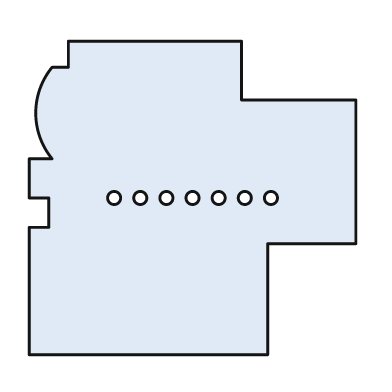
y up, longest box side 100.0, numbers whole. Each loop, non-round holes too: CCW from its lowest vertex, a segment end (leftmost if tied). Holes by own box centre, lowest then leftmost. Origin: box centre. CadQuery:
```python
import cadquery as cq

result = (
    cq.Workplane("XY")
    .moveTo(-50.0, -48.0)
    .lineTo(23.0, -48.0)
    .lineTo(23.0, -14.0)
    .lineTo(50.0, -14.0)
    .lineTo(50.0, 30.0)
    .lineTo(15.0, 30.0)
    .lineTo(15.0, 48.0)
    .lineTo(-38.0, 48.0)
    .lineTo(-38.0, 40.0)
    .lineTo(-43.0, 40.0)
    .threePointArc((-48.0, 26.0), (-43.0, 12.0))
    .lineTo(-50.0, 12.0)
    .lineTo(-50.0, 0.0)
    .lineTo(-44.0, 0.0)
    .lineTo(-44.0, -9.0)
    .lineTo(-50.0, -9.0)
    .close()
    .moveTo(-24.0, 0.0)
    .circle(2.0)
    .moveTo(-16.0, 0.0)
    .circle(2.0)
    .moveTo(-8.0, 0.0)
    .circle(2.0)
    .moveTo(0.0, 0.0)
    .circle(2.0)
    .moveTo(8.0, 0.0)
    .circle(2.0)
    .moveTo(16.0, 0.0)
    .circle(2.0)
    .moveTo(24.0, 0.0)
    .circle(2.0)
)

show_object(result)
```